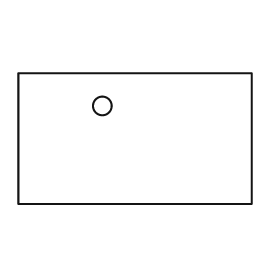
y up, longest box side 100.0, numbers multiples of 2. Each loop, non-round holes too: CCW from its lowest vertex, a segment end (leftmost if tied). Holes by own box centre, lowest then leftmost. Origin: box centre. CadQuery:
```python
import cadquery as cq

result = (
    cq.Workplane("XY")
    .moveTo(-50.0, -28.0)
    .lineTo(50.0, -28.0)
    .lineTo(50.0, 28.0)
    .lineTo(-50.0, 28.0)
    .close()
    .moveTo(-14.0, 14.0)
    .circle(4.0)
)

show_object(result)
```